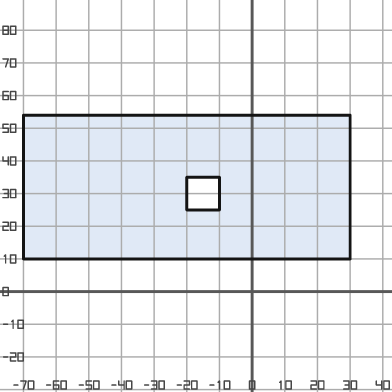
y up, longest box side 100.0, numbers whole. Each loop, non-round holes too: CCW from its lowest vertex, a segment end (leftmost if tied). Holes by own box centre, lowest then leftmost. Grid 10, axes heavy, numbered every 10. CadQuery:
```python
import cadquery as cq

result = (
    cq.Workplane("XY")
    .moveTo(-70.0, 10.0)
    .lineTo(30.0, 10.0)
    .lineTo(30.0, 54.0)
    .lineTo(-70.0, 54.0)
    .close()
    .moveTo(-20.0, 25.0)
    .lineTo(-10.0, 25.0)
    .lineTo(-10.0, 35.0)
    .lineTo(-20.0, 35.0)
    .close()
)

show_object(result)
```